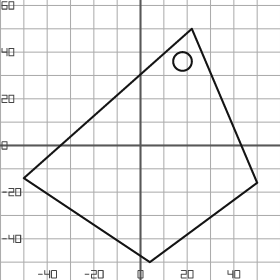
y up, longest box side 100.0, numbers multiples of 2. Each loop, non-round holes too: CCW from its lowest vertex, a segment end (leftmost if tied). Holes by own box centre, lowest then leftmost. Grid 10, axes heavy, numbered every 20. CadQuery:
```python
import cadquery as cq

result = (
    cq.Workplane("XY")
    .moveTo(4.0, -50.0)
    .lineTo(50.0, -16.0)
    .lineTo(22.0, 50.0)
    .lineTo(-50.0, -14.0)
    .close()
    .moveTo(18.0, 36.0)
    .circle(4.0)
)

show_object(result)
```